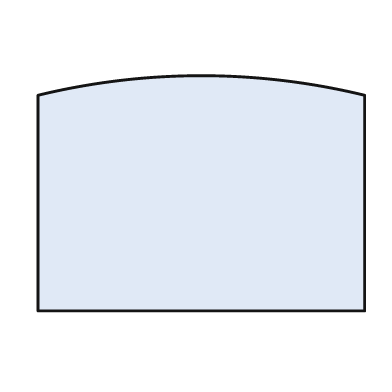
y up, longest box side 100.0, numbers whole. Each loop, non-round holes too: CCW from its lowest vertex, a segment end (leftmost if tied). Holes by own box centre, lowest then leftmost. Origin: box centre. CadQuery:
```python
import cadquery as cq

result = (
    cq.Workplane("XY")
    .moveTo(-50.0, -36.0)
    .lineTo(50.0, -36.0)
    .lineTo(50.0, 30.0)
    .threePointArc((0.0, 36.0), (-50.0, 30.0))
    .close()
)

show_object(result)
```